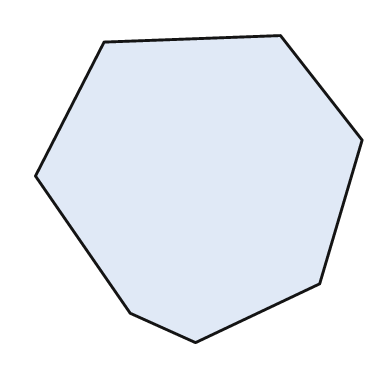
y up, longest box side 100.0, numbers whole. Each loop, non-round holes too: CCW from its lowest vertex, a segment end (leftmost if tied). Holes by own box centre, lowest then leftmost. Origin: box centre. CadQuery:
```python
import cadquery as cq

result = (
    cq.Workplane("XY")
    .moveTo(-1.0, -47.0)
    .lineTo(37.0, -29.0)
    .lineTo(50.0, 15.0)
    .lineTo(25.0, 47.0)
    .lineTo(-29.0, 45.0)
    .lineTo(-50.0, 4.0)
    .lineTo(-21.0, -38.0)
    .close()
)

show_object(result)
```